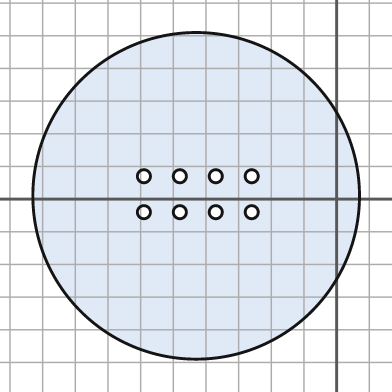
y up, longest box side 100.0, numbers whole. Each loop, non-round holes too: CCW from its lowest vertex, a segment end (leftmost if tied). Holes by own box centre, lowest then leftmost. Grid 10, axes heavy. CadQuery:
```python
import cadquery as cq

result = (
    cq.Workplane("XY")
    .moveTo(-43.0, 1.0)
    .circle(50.0)
    .moveTo(-59.0, -4.0)
    .circle(2.0)
    .moveTo(-48.0, -4.0)
    .circle(2.0)
    .moveTo(-37.0, -4.0)
    .circle(2.0)
    .moveTo(-26.0, -4.0)
    .circle(2.0)
    .moveTo(-59.0, 7.0)
    .circle(2.0)
    .moveTo(-48.0, 7.0)
    .circle(2.0)
    .moveTo(-37.0, 7.0)
    .circle(2.0)
    .moveTo(-26.0, 7.0)
    .circle(2.0)
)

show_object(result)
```